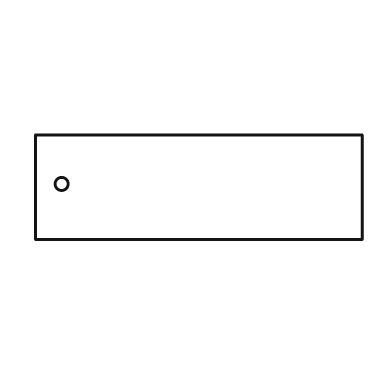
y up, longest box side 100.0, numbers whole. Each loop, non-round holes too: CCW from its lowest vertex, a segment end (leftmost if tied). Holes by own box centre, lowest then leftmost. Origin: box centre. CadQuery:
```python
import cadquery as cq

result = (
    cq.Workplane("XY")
    .moveTo(-50.0, -16.0)
    .lineTo(50.0, -16.0)
    .lineTo(50.0, 16.0)
    .lineTo(-50.0, 16.0)
    .close()
    .moveTo(-42.0, 1.0)
    .circle(2.0)
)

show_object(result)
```